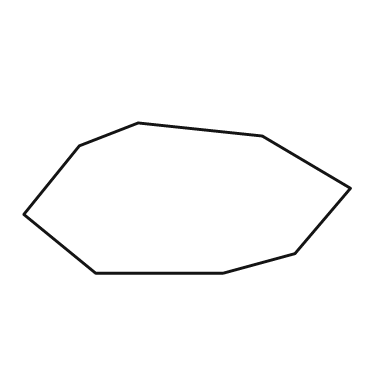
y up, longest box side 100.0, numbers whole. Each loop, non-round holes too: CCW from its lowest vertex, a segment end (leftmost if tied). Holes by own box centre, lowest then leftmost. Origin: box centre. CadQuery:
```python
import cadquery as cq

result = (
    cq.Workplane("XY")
    .moveTo(-28.0, -23.0)
    .lineTo(11.0, -23.0)
    .lineTo(33.0, -17.0)
    .lineTo(50.0, 3.0)
    .lineTo(23.0, 19.0)
    .lineTo(-15.0, 23.0)
    .lineTo(-33.0, 16.0)
    .lineTo(-50.0, -5.0)
    .close()
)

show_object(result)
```